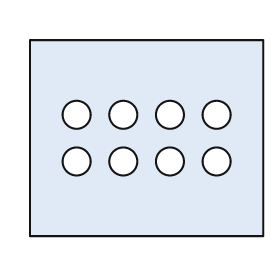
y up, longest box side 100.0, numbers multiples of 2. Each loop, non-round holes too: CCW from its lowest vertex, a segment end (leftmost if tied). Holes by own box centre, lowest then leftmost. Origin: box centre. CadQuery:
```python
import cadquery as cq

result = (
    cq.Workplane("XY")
    .moveTo(-50.0, -42.0)
    .lineTo(50.0, -42.0)
    .lineTo(50.0, 42.0)
    .lineTo(-50.0, 42.0)
    .close()
    .moveTo(-30.0, -10.0)
    .circle(6.0)
    .moveTo(-10.0, -10.0)
    .circle(6.0)
    .moveTo(10.0, -10.0)
    .circle(6.0)
    .moveTo(30.0, -10.0)
    .circle(6.0)
    .moveTo(-30.0, 10.0)
    .circle(6.0)
    .moveTo(-10.0, 10.0)
    .circle(6.0)
    .moveTo(10.0, 10.0)
    .circle(6.0)
    .moveTo(30.0, 10.0)
    .circle(6.0)
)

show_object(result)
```